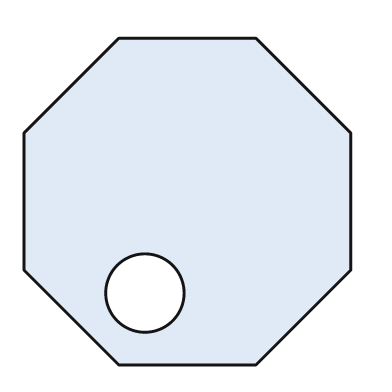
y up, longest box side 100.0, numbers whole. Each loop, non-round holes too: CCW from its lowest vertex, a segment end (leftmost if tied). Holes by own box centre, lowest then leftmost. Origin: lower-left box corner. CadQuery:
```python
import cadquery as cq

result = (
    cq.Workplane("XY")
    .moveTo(29.0, 0.0)
    .lineTo(71.0, 0.0)
    .lineTo(100.0, 29.0)
    .lineTo(100.0, 71.0)
    .lineTo(71.0, 100.0)
    .lineTo(29.0, 100.0)
    .lineTo(0.0, 71.0)
    .lineTo(0.0, 29.0)
    .close()
    .moveTo(37.0, 22.0)
    .circle(12.0)
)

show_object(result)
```